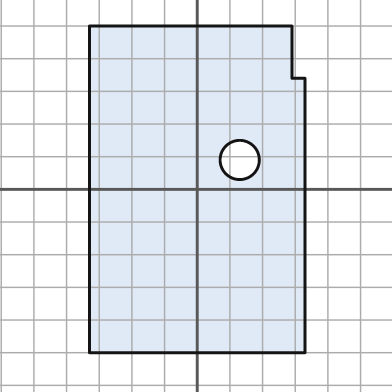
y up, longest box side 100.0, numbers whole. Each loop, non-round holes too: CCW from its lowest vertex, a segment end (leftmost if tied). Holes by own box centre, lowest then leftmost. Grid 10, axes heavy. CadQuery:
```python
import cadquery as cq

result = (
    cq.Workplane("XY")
    .moveTo(-33.0, -50.0)
    .lineTo(33.0, -50.0)
    .lineTo(33.0, 34.0)
    .lineTo(29.0, 34.0)
    .lineTo(29.0, 50.0)
    .lineTo(-33.0, 50.0)
    .close()
    .moveTo(13.0, 9.0)
    .circle(6.0)
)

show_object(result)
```